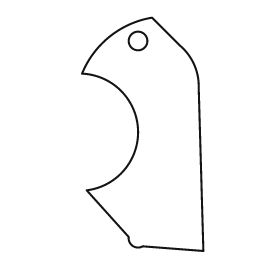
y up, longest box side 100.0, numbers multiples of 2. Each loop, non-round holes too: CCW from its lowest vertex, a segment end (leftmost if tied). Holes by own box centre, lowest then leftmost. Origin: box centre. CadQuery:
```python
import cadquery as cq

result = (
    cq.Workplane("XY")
    .moveTo(26.0, -50.0)
    .lineTo(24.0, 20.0)
    .threePointArc((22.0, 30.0), (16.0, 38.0))
    .lineTo(4.0, 50.0)
    .threePointArc((-14.0, 42.0), (-26.0, 26.0))
    .threePointArc((-2.0, 2.0), (-24.0, -24.0))
    .lineTo(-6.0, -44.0)
    .threePointArc((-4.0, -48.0), (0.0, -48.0))
    .close()
    .moveTo(-2.0, 40.0)
    .circle(4.0)
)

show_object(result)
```